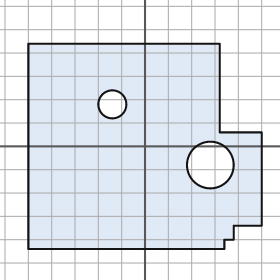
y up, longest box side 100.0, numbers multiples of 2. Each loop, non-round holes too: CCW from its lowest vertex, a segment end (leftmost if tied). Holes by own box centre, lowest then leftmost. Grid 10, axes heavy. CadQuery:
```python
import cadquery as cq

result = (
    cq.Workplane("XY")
    .moveTo(-50.0, -44.0)
    .lineTo(34.0, -44.0)
    .lineTo(34.0, -40.0)
    .lineTo(38.0, -40.0)
    .lineTo(38.0, -34.0)
    .lineTo(50.0, -34.0)
    .lineTo(50.0, 6.0)
    .lineTo(32.0, 6.0)
    .lineTo(32.0, 44.0)
    .lineTo(-50.0, 44.0)
    .close()
    .moveTo(28.0, -8.0)
    .circle(10.0)
    .moveTo(-14.0, 18.0)
    .circle(6.0)
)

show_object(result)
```